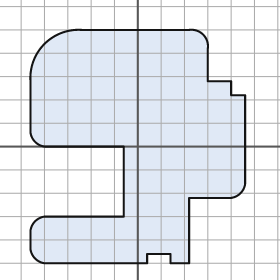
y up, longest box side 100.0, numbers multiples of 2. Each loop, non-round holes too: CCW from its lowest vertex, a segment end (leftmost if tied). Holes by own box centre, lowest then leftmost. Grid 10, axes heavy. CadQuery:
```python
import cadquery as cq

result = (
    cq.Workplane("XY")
    .moveTo(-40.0, -50.0)
    .lineTo(4.0, -50.0)
    .lineTo(4.0, -46.0)
    .lineTo(14.0, -46.0)
    .lineTo(14.0, -50.0)
    .lineTo(22.0, -50.0)
    .lineTo(22.0, -22.0)
    .lineTo(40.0, -22.0)
    .threePointArc((44.0, -20.0), (46.0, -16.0))
    .lineTo(46.0, 22.0)
    .lineTo(40.0, 22.0)
    .lineTo(40.0, 28.0)
    .lineTo(30.0, 28.0)
    .lineTo(30.0, 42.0)
    .threePointArc((28.0, 48.0), (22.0, 50.0))
    .lineTo(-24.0, 50.0)
    .threePointArc((-40.0, 44.0), (-46.0, 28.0))
    .lineTo(-46.0, 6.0)
    .threePointArc((-44.0, 2.0), (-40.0, 0.0))
    .lineTo(-6.0, 0.0)
    .lineTo(-6.0, -30.0)
    .lineTo(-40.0, -30.0)
    .threePointArc((-44.0, -32.0), (-46.0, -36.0))
    .lineTo(-46.0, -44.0)
    .threePointArc((-44.0, -48.0), (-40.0, -50.0))
    .close()
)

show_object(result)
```